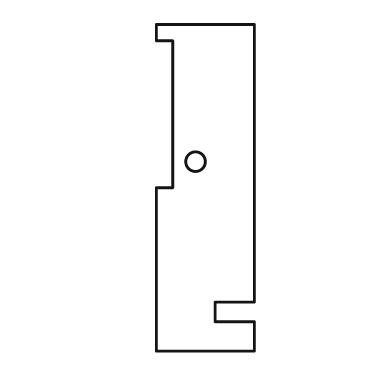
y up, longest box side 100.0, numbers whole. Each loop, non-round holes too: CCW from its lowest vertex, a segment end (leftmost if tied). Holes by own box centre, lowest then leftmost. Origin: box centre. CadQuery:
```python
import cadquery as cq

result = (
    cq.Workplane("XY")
    .moveTo(-15.0, -50.0)
    .lineTo(15.0, -50.0)
    .lineTo(15.0, -41.0)
    .lineTo(3.0, -41.0)
    .lineTo(3.0, -35.0)
    .lineTo(15.0, -35.0)
    .lineTo(15.0, 50.0)
    .lineTo(-15.0, 50.0)
    .lineTo(-15.0, 45.0)
    .lineTo(-10.0, 45.0)
    .lineTo(-10.0, 0.0)
    .lineTo(-15.0, 0.0)
    .close()
    .moveTo(-3.0, 8.0)
    .circle(3.0)
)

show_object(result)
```